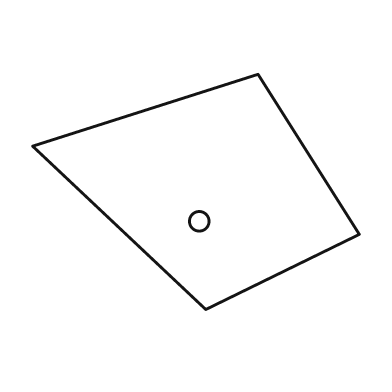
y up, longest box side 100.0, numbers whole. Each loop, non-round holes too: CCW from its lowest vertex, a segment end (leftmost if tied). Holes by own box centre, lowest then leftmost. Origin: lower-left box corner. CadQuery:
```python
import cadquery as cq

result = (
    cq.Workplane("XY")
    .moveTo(53.0, 0.0)
    .lineTo(100.0, 23.0)
    .lineTo(69.0, 72.0)
    .lineTo(0.0, 50.0)
    .close()
    .moveTo(51.0, 27.0)
    .circle(3.0)
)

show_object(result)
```